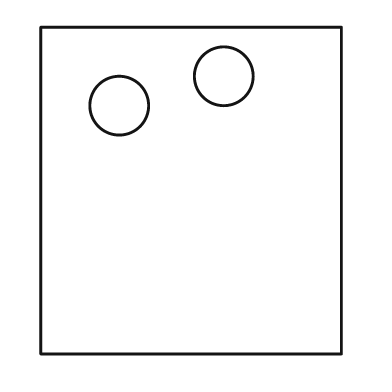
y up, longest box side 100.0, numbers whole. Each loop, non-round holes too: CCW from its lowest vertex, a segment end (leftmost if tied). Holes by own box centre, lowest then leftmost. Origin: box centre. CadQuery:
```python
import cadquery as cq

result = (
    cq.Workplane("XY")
    .moveTo(-46.0, -50.0)
    .lineTo(46.0, -50.0)
    .lineTo(46.0, 50.0)
    .lineTo(-46.0, 50.0)
    .close()
    .moveTo(-22.0, 26.0)
    .circle(9.0)
    .moveTo(10.0, 35.0)
    .circle(9.0)
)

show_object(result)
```